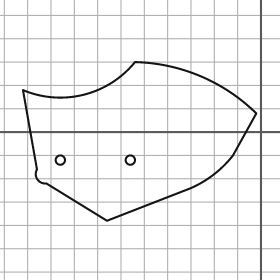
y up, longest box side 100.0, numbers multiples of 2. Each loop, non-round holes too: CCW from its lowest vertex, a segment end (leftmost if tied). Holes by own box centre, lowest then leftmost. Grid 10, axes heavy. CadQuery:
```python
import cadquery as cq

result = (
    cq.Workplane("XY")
    .moveTo(-66.0, -38.0)
    .lineTo(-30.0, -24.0)
    .threePointArc((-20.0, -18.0), (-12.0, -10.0))
    .lineTo(-2.0, 8.0)
    .threePointArc((-26.0, 24.0), (-54.0, 30.0))
    .threePointArc((-76.0, 16.0), (-102.0, 18.0))
    .lineTo(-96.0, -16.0)
    .threePointArc((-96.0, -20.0), (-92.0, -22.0))
    .close()
    .moveTo(-86.0, -12.0)
    .circle(2.0)
    .moveTo(-56.0, -12.0)
    .circle(2.0)
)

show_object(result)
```